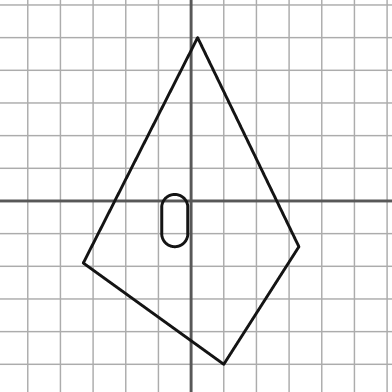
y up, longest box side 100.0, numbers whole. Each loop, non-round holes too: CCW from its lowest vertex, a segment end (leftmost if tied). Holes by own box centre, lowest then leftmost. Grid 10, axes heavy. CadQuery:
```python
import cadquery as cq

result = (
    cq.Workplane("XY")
    .moveTo(10.0, -50.0)
    .lineTo(33.0, -14.0)
    .lineTo(2.0, 50.0)
    .lineTo(-33.0, -19.0)
    .close()
    .moveTo(-9.0, -10.0)
    .threePointArc((-5.0, -14.0), (-1.0, -10.0))
    .lineTo(-1.0, -2.0)
    .threePointArc((-5.0, 2.0), (-9.0, -2.0))
    .close()
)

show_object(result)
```